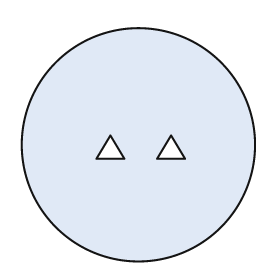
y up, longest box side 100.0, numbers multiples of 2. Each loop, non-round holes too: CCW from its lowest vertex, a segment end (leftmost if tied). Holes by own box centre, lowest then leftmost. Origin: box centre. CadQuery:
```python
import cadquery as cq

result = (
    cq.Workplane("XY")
    .moveTo(0.0, 0.0)
    .circle(50.0)
    .moveTo(-18.0, -6.0)
    .lineTo(-6.0, -6.0)
    .lineTo(-12.0, 4.0)
    .close()
    .moveTo(8.0, -6.0)
    .lineTo(20.0, -6.0)
    .lineTo(14.0, 4.0)
    .close()
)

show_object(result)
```